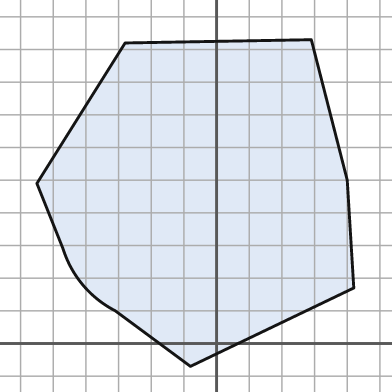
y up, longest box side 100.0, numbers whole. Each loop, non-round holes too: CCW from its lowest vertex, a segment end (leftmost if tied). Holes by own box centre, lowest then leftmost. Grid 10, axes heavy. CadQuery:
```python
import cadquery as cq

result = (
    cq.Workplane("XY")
    .moveTo(-8.0, -7.0)
    .lineTo(42.0, 17.0)
    .lineTo(40.0, 50.0)
    .lineTo(29.0, 93.0)
    .lineTo(-28.0, 92.0)
    .lineTo(-55.0, 49.0)
    .lineTo(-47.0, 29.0)
    .threePointArc((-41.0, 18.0), (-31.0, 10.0))
    .close()
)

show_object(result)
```